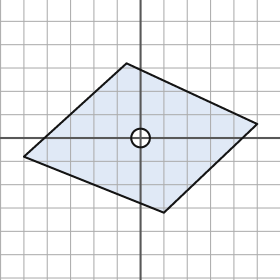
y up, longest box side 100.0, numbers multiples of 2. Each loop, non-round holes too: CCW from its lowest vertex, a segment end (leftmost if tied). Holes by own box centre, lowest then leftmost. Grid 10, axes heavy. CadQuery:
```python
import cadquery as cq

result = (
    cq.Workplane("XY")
    .moveTo(10.0, -32.0)
    .lineTo(50.0, 6.0)
    .lineTo(-6.0, 32.0)
    .lineTo(-50.0, -8.0)
    .close()
    .moveTo(0.0, 0.0)
    .circle(4.0)
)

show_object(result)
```